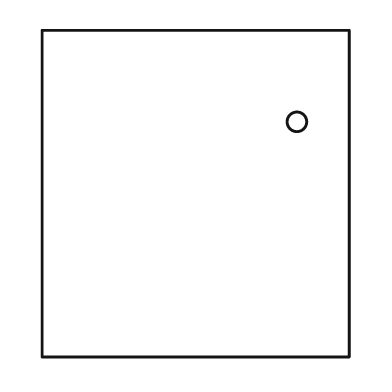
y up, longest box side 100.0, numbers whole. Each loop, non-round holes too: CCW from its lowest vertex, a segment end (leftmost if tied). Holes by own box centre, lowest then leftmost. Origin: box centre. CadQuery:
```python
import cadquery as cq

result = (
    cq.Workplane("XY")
    .moveTo(-47.0, -50.0)
    .lineTo(47.0, -50.0)
    .lineTo(47.0, 50.0)
    .lineTo(-47.0, 50.0)
    .close()
    .moveTo(31.0, 22.0)
    .circle(3.0)
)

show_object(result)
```